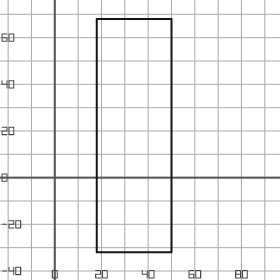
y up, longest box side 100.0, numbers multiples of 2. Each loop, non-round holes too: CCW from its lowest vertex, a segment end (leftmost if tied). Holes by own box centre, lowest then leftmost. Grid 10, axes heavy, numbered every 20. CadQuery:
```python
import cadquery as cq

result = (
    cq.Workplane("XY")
    .moveTo(18.0, -32.0)
    .lineTo(50.0, -32.0)
    .lineTo(50.0, 68.0)
    .lineTo(18.0, 68.0)
    .close()
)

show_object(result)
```